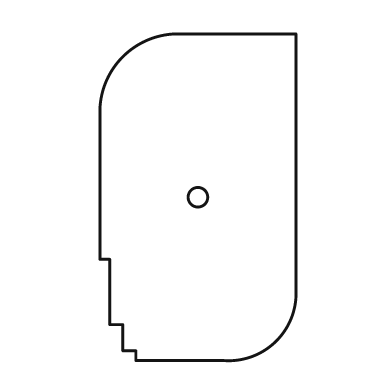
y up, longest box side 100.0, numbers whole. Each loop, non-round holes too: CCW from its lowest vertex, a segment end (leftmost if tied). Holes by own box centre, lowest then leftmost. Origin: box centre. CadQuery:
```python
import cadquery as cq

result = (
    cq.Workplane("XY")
    .moveTo(-19.0, -50.0)
    .lineTo(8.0, -50.0)
    .threePointArc((24.0, -44.0), (30.0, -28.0))
    .lineTo(30.0, 50.0)
    .lineTo(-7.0, 50.0)
    .threePointArc((-23.0, 43.0), (-30.0, 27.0))
    .lineTo(-30.0, -19.0)
    .lineTo(-27.0, -19.0)
    .lineTo(-27.0, -39.0)
    .lineTo(-23.0, -39.0)
    .lineTo(-23.0, -47.0)
    .lineTo(-19.0, -47.0)
    .close()
    .moveTo(0.0, 0.0)
    .circle(3.0)
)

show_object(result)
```